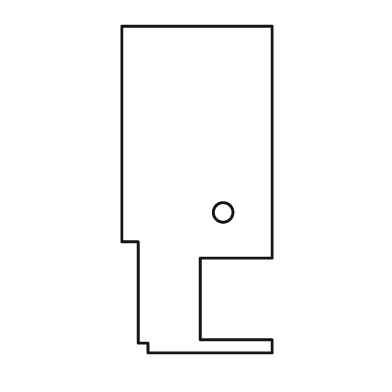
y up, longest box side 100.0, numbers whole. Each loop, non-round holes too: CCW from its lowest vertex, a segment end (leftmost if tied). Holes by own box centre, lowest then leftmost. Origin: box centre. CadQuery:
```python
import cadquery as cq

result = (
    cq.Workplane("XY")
    .moveTo(-15.0, -50.0)
    .lineTo(23.0, -50.0)
    .lineTo(23.0, -46.0)
    .lineTo(1.0, -46.0)
    .lineTo(1.0, -21.0)
    .lineTo(23.0, -21.0)
    .lineTo(23.0, 50.0)
    .lineTo(-23.0, 50.0)
    .lineTo(-23.0, -16.0)
    .lineTo(-18.0, -16.0)
    .lineTo(-18.0, -47.0)
    .lineTo(-15.0, -47.0)
    .close()
    .moveTo(8.0, -7.0)
    .circle(3.0)
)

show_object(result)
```